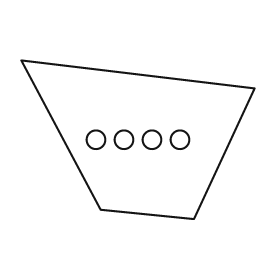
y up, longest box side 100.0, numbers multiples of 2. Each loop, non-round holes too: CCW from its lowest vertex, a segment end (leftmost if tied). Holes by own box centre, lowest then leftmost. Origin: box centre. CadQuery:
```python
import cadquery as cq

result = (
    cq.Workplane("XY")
    .moveTo(24.0, -34.0)
    .lineTo(50.0, 22.0)
    .lineTo(-50.0, 34.0)
    .lineTo(-16.0, -30.0)
    .close()
    .moveTo(-18.0, 0.0)
    .circle(4.0)
    .moveTo(-6.0, 0.0)
    .circle(4.0)
    .moveTo(6.0, 0.0)
    .circle(4.0)
    .moveTo(18.0, 0.0)
    .circle(4.0)
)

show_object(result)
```